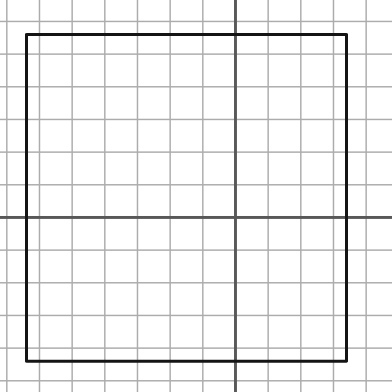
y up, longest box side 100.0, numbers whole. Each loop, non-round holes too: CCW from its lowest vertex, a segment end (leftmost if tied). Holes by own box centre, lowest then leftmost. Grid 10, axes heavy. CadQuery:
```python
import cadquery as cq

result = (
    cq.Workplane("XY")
    .moveTo(-64.0, -44.0)
    .lineTo(34.0, -44.0)
    .lineTo(34.0, 56.0)
    .lineTo(-64.0, 56.0)
    .close()
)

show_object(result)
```